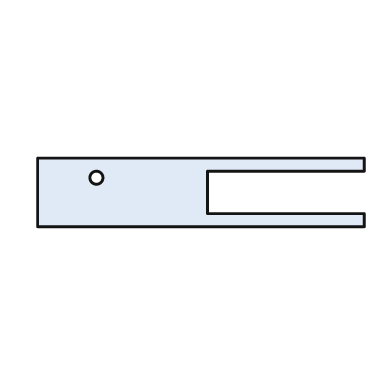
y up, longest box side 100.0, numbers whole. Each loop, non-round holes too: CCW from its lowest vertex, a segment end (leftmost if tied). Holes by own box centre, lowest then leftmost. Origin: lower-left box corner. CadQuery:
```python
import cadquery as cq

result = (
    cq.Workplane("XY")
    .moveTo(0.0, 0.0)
    .lineTo(100.0, 0.0)
    .lineTo(100.0, 4.0)
    .lineTo(52.0, 4.0)
    .lineTo(52.0, 17.0)
    .lineTo(100.0, 17.0)
    .lineTo(100.0, 21.0)
    .lineTo(0.0, 21.0)
    .close()
    .moveTo(18.0, 15.0)
    .circle(2.0)
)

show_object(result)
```